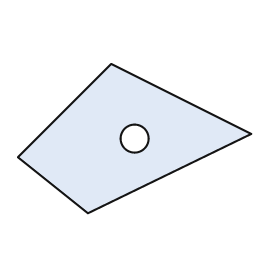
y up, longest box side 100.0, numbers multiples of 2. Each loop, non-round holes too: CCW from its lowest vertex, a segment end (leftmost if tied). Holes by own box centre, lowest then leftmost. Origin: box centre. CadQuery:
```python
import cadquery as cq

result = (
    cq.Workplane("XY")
    .moveTo(-20.0, -32.0)
    .lineTo(50.0, 2.0)
    .lineTo(-10.0, 32.0)
    .lineTo(-50.0, -8.0)
    .close()
    .moveTo(0.0, 0.0)
    .circle(6.0)
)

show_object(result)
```